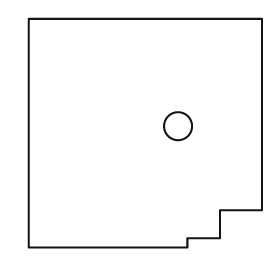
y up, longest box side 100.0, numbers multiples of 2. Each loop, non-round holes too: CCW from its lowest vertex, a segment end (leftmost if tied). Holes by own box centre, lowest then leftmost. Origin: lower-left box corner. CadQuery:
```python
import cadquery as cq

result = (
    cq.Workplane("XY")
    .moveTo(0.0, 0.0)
    .lineTo(68.0, 0.0)
    .lineTo(68.0, 4.0)
    .lineTo(82.0, 4.0)
    .lineTo(82.0, 16.0)
    .lineTo(100.0, 16.0)
    .lineTo(100.0, 98.0)
    .lineTo(0.0, 98.0)
    .close()
    .moveTo(64.0, 52.0)
    .circle(6.0)
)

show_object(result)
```